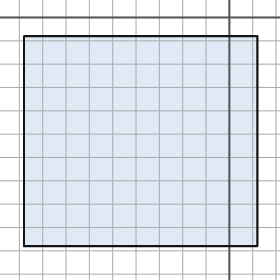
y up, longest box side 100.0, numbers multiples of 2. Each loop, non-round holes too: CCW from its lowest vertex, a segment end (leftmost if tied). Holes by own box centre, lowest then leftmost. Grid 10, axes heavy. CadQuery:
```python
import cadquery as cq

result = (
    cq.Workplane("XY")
    .moveTo(-88.0, -98.0)
    .lineTo(12.0, -98.0)
    .lineTo(12.0, -8.0)
    .lineTo(-88.0, -8.0)
    .close()
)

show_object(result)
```